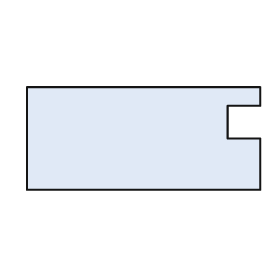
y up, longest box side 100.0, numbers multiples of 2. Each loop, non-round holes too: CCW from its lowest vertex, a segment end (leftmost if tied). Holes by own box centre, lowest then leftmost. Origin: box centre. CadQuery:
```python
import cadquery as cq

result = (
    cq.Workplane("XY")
    .moveTo(-50.0, -22.0)
    .lineTo(50.0, -22.0)
    .lineTo(50.0, 0.0)
    .lineTo(36.0, 0.0)
    .lineTo(36.0, 14.0)
    .lineTo(50.0, 14.0)
    .lineTo(50.0, 22.0)
    .lineTo(-50.0, 22.0)
    .close()
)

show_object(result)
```